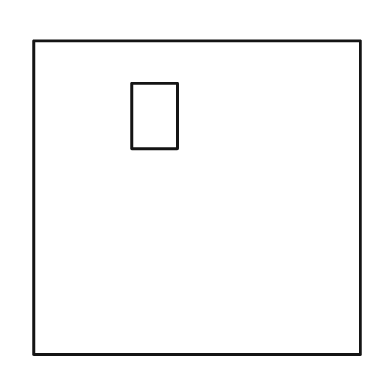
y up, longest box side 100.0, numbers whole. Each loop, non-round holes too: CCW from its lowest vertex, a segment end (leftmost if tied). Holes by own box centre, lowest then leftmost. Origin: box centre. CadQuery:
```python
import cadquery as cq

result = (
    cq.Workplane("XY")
    .moveTo(-50.0, -48.0)
    .lineTo(50.0, -48.0)
    .lineTo(50.0, 48.0)
    .lineTo(-50.0, 48.0)
    .close()
    .moveTo(-20.0, 15.0)
    .lineTo(-6.0, 15.0)
    .lineTo(-6.0, 35.0)
    .lineTo(-20.0, 35.0)
    .close()
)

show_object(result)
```